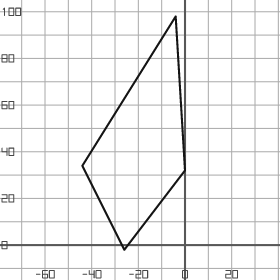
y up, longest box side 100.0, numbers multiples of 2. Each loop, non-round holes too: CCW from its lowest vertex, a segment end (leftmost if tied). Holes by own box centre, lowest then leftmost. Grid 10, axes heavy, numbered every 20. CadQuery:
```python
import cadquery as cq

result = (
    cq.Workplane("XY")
    .moveTo(-26.0, -2.0)
    .lineTo(0.0, 32.0)
    .lineTo(-4.0, 98.0)
    .lineTo(-44.0, 34.0)
    .close()
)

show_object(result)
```